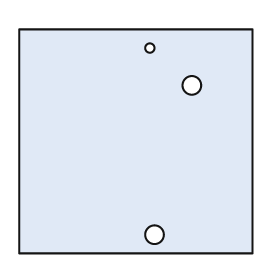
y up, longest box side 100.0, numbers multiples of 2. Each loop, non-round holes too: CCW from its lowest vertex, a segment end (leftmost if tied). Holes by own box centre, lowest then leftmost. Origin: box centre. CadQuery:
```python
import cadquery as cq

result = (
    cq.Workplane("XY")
    .moveTo(-50.0, -48.0)
    .lineTo(50.0, -48.0)
    .lineTo(50.0, 48.0)
    .lineTo(-50.0, 48.0)
    .close()
    .moveTo(8.0, -40.0)
    .circle(4.0)
    .moveTo(24.0, 24.0)
    .circle(4.0)
    .moveTo(6.0, 40.0)
    .circle(2.0)
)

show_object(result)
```